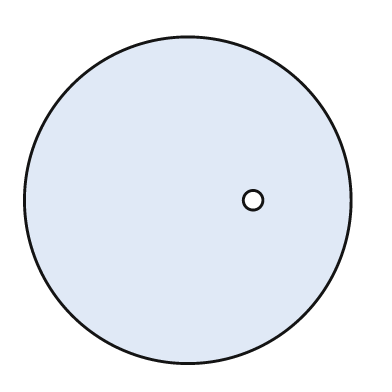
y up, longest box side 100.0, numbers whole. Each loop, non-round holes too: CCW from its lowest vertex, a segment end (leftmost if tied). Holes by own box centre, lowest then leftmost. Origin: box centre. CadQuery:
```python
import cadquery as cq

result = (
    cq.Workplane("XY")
    .moveTo(0.0, 0.0)
    .circle(50.0)
    .moveTo(20.0, 0.0)
    .circle(3.0)
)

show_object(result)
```